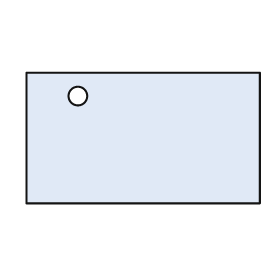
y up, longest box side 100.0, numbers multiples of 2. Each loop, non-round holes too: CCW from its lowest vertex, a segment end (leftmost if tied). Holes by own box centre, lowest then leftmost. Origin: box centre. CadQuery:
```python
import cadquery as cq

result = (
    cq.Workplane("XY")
    .moveTo(-50.0, -28.0)
    .lineTo(50.0, -28.0)
    .lineTo(50.0, 28.0)
    .lineTo(-50.0, 28.0)
    .close()
    .moveTo(-28.0, 18.0)
    .circle(4.0)
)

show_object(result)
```